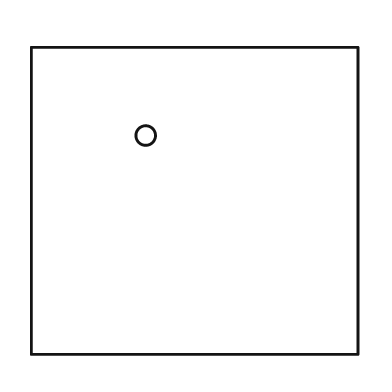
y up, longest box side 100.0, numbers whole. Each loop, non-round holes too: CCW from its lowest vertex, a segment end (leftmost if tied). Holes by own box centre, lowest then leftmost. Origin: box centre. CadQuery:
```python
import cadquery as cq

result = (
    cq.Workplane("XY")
    .moveTo(-50.0, -47.0)
    .lineTo(50.0, -47.0)
    .lineTo(50.0, 47.0)
    .lineTo(-50.0, 47.0)
    .close()
    .moveTo(-15.0, 20.0)
    .circle(3.0)
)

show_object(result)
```